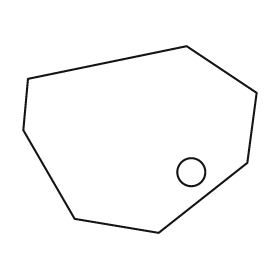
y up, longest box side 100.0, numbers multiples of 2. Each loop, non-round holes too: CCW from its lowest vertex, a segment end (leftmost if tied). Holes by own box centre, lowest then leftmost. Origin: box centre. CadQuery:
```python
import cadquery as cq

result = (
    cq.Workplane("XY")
    .moveTo(8.0, -40.0)
    .lineTo(46.0, -10.0)
    .lineTo(50.0, 20.0)
    .lineTo(20.0, 40.0)
    .lineTo(-48.0, 26.0)
    .lineTo(-50.0, 4.0)
    .lineTo(-28.0, -34.0)
    .close()
    .moveTo(22.0, -14.0)
    .circle(6.0)
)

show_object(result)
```